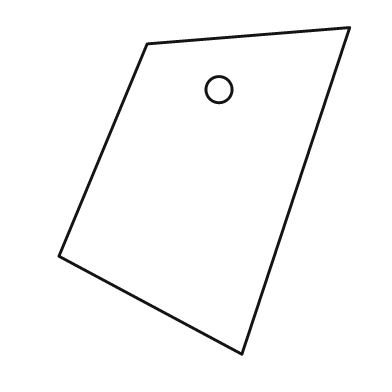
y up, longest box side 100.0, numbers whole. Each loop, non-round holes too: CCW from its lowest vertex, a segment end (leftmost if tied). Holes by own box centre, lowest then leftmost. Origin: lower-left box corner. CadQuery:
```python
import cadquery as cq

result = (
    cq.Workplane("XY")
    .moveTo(56.0, 0.0)
    .lineTo(89.0, 100.0)
    .lineTo(27.0, 95.0)
    .lineTo(0.0, 30.0)
    .close()
    .moveTo(49.0, 81.0)
    .circle(4.0)
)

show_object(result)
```